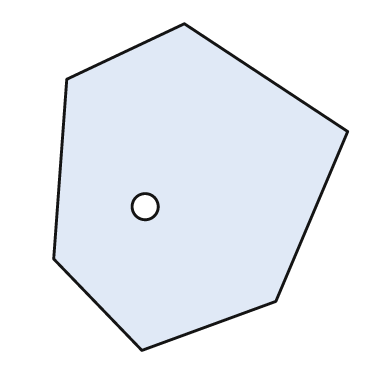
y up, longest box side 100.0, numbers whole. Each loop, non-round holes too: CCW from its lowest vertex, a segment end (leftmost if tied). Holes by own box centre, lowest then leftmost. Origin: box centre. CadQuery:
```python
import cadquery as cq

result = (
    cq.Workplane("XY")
    .moveTo(-18.0, -50.0)
    .lineTo(23.0, -35.0)
    .lineTo(45.0, 17.0)
    .lineTo(-5.0, 50.0)
    .lineTo(-41.0, 33.0)
    .lineTo(-45.0, -22.0)
    .close()
    .moveTo(-17.0, -6.0)
    .circle(4.0)
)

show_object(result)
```